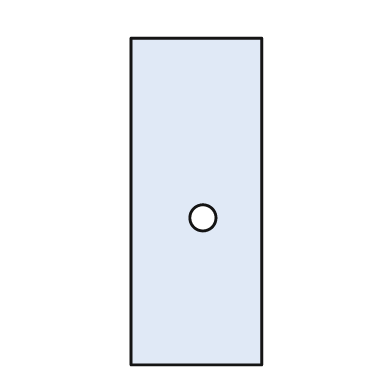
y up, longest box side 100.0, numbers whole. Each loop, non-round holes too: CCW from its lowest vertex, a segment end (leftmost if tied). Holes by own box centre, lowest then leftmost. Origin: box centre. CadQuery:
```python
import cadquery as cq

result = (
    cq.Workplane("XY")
    .moveTo(-20.0, -50.0)
    .lineTo(20.0, -50.0)
    .lineTo(20.0, 50.0)
    .lineTo(-20.0, 50.0)
    .close()
    .moveTo(2.0, -5.0)
    .circle(4.0)
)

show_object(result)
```